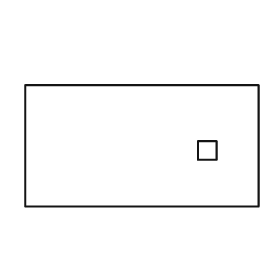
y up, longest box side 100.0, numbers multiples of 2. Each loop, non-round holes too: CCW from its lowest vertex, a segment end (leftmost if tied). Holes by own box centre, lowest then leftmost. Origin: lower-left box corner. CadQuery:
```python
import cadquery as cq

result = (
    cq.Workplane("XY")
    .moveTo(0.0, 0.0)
    .lineTo(100.0, 0.0)
    .lineTo(100.0, 52.0)
    .lineTo(0.0, 52.0)
    .close()
    .moveTo(74.0, 20.0)
    .lineTo(82.0, 20.0)
    .lineTo(82.0, 28.0)
    .lineTo(74.0, 28.0)
    .close()
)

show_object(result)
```